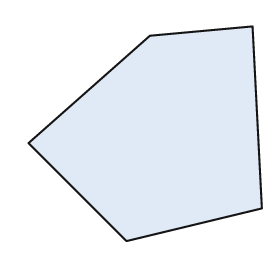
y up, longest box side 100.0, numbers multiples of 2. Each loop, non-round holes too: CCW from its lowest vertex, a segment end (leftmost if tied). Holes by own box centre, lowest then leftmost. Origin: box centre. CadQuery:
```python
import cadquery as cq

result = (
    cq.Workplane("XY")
    .moveTo(-8.0, -46.0)
    .lineTo(50.0, -32.0)
    .lineTo(46.0, 46.0)
    .lineTo(2.0, 42.0)
    .lineTo(-50.0, -4.0)
    .close()
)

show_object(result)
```